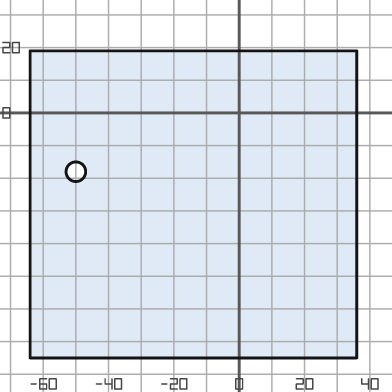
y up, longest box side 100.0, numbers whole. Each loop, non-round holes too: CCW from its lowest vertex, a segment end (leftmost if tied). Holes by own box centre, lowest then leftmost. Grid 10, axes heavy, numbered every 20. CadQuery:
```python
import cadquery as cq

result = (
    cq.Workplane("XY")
    .moveTo(-64.0, -75.0)
    .lineTo(36.0, -75.0)
    .lineTo(36.0, 19.0)
    .lineTo(-64.0, 19.0)
    .close()
    .moveTo(-50.0, -18.0)
    .circle(3.0)
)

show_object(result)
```